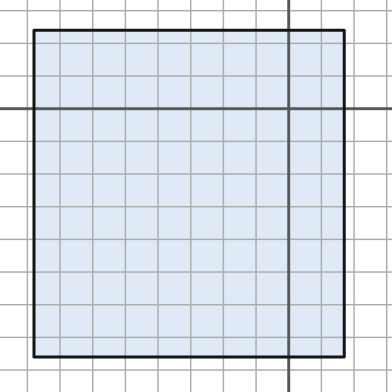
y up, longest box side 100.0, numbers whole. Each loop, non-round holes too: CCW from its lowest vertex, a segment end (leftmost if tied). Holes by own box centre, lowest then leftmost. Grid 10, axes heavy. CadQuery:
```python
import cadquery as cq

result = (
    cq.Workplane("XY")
    .moveTo(-78.0, -76.0)
    .lineTo(17.0, -76.0)
    .lineTo(17.0, 24.0)
    .lineTo(-78.0, 24.0)
    .close()
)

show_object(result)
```